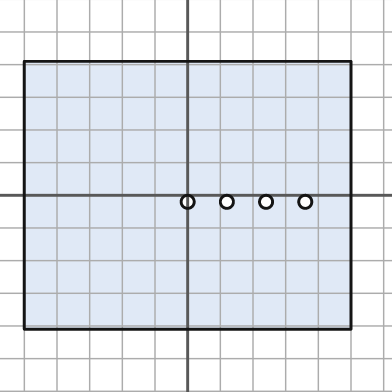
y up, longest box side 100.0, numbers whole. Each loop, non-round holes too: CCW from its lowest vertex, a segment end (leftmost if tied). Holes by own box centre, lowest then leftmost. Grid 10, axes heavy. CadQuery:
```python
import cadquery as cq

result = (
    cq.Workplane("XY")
    .moveTo(-50.0, -41.0)
    .lineTo(50.0, -41.0)
    .lineTo(50.0, 41.0)
    .lineTo(-50.0, 41.0)
    .close()
    .moveTo(0.0, -2.0)
    .circle(2.0)
    .moveTo(12.0, -2.0)
    .circle(2.0)
    .moveTo(24.0, -2.0)
    .circle(2.0)
    .moveTo(36.0, -2.0)
    .circle(2.0)
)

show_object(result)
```